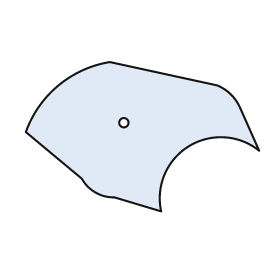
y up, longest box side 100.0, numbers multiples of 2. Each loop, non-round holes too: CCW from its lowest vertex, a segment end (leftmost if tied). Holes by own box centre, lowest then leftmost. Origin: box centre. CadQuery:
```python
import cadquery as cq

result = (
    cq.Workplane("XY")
    .moveTo(8.0, -32.0)
    .threePointArc((20.0, -4.0), (50.0, -6.0))
    .lineTo(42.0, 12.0)
    .threePointArc((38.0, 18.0), (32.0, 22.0))
    .lineTo(-14.0, 32.0)
    .threePointArc((-36.0, 22.0), (-50.0, 2.0))
    .lineTo(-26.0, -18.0)
    .threePointArc((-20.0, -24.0), (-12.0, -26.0))
    .close()
    .moveTo(-8.0, 6.0)
    .circle(2.0)
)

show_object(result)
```